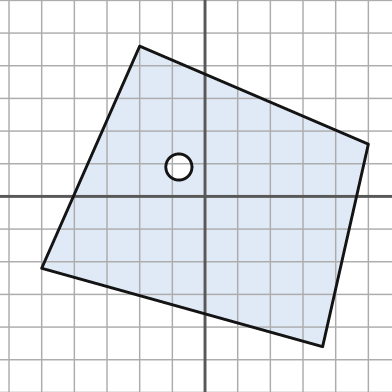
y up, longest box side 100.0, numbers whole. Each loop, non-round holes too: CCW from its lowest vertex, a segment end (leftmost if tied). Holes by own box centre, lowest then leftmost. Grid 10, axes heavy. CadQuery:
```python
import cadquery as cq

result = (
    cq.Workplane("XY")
    .moveTo(36.0, -46.0)
    .lineTo(50.0, 16.0)
    .lineTo(-20.0, 46.0)
    .lineTo(-50.0, -22.0)
    .close()
    .moveTo(-8.0, 9.0)
    .circle(4.0)
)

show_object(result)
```